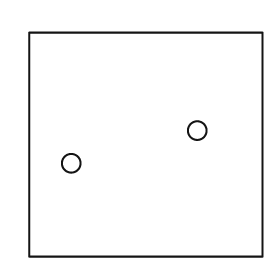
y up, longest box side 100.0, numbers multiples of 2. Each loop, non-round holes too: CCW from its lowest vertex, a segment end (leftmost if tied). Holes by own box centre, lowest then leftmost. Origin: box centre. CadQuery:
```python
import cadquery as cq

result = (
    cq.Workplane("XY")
    .moveTo(-50.0, -48.0)
    .lineTo(50.0, -48.0)
    .lineTo(50.0, 48.0)
    .lineTo(-50.0, 48.0)
    .close()
    .moveTo(-32.0, -8.0)
    .circle(4.0)
    .moveTo(22.0, 6.0)
    .circle(4.0)
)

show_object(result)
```